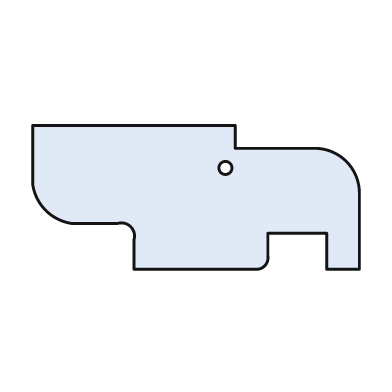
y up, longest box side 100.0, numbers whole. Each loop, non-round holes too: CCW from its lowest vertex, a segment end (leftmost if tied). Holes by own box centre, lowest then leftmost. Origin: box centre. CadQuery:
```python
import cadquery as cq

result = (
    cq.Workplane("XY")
    .moveTo(-19.0, -22.0)
    .lineTo(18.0, -22.0)
    .threePointArc((21.0, -21.0), (22.0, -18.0))
    .lineTo(22.0, -11.0)
    .lineTo(40.0, -11.0)
    .lineTo(40.0, -22.0)
    .lineTo(50.0, -22.0)
    .lineTo(50.0, 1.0)
    .threePointArc((46.0, 11.0), (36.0, 15.0))
    .lineTo(12.0, 15.0)
    .lineTo(12.0, 22.0)
    .lineTo(-50.0, 22.0)
    .lineTo(-50.0, 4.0)
    .threePointArc((-46.0, -4.0), (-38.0, -8.0))
    .lineTo(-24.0, -8.0)
    .threePointArc((-20.0, -9.0), (-19.0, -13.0))
    .close()
    .moveTo(9.0, 9.0)
    .circle(2.0)
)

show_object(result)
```